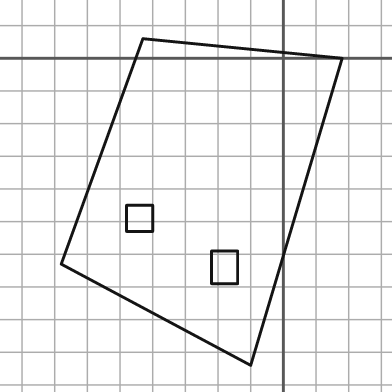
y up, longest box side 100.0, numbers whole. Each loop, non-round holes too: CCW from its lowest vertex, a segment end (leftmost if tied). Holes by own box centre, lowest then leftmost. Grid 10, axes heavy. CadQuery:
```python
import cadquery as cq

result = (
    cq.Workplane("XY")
    .moveTo(-10.0, -94.0)
    .lineTo(18.0, 0.0)
    .lineTo(-43.0, 6.0)
    .lineTo(-68.0, -63.0)
    .close()
    .moveTo(-22.0, -69.0)
    .lineTo(-14.0, -69.0)
    .lineTo(-14.0, -59.0)
    .lineTo(-22.0, -59.0)
    .close()
    .moveTo(-48.0, -53.0)
    .lineTo(-40.0, -53.0)
    .lineTo(-40.0, -45.0)
    .lineTo(-48.0, -45.0)
    .close()
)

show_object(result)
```